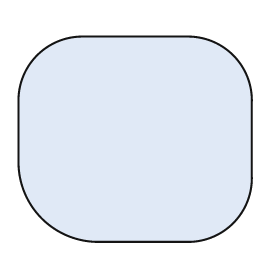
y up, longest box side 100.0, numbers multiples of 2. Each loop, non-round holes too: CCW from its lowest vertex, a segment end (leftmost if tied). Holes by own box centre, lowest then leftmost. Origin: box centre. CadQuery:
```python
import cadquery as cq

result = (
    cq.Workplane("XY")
    .moveTo(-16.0, -44.0)
    .lineTo(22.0, -44.0)
    .threePointArc((42.0, -36.0), (50.0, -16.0))
    .lineTo(50.0, 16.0)
    .threePointArc((42.0, 36.0), (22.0, 44.0))
    .lineTo(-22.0, 44.0)
    .threePointArc((-42.0, 36.0), (-50.0, 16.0))
    .lineTo(-50.0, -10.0)
    .threePointArc((-40.0, -34.0), (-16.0, -44.0))
    .close()
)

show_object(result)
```